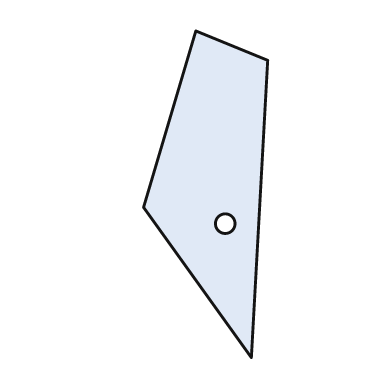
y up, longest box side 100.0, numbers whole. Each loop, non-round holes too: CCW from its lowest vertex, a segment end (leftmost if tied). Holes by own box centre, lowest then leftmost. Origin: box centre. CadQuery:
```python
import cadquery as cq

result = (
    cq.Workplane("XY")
    .moveTo(14.0, -50.0)
    .lineTo(19.0, 41.0)
    .lineTo(-3.0, 50.0)
    .lineTo(-19.0, -4.0)
    .close()
    .moveTo(6.0, -9.0)
    .circle(3.0)
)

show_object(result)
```